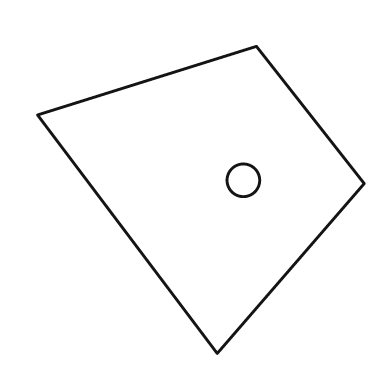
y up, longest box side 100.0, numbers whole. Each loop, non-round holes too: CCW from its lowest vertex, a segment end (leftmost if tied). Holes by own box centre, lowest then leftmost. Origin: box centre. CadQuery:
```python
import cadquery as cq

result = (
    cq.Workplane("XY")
    .moveTo(5.0, -47.0)
    .lineTo(50.0, 5.0)
    .lineTo(17.0, 47.0)
    .lineTo(-50.0, 26.0)
    .close()
    .moveTo(13.0, 6.0)
    .circle(5.0)
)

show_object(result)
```